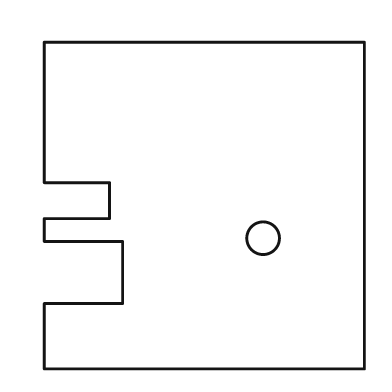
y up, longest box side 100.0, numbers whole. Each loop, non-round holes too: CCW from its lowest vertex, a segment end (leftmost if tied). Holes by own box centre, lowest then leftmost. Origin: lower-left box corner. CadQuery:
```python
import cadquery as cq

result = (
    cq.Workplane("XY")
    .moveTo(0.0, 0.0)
    .lineTo(98.0, 0.0)
    .lineTo(98.0, 100.0)
    .lineTo(0.0, 100.0)
    .lineTo(0.0, 57.0)
    .lineTo(20.0, 57.0)
    .lineTo(20.0, 46.0)
    .lineTo(0.0, 46.0)
    .lineTo(0.0, 39.0)
    .lineTo(24.0, 39.0)
    .lineTo(24.0, 20.0)
    .lineTo(0.0, 20.0)
    .close()
    .moveTo(67.0, 40.0)
    .circle(5.0)
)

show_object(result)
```